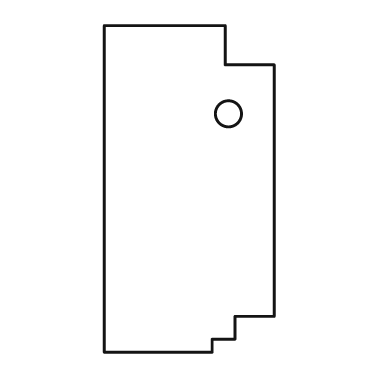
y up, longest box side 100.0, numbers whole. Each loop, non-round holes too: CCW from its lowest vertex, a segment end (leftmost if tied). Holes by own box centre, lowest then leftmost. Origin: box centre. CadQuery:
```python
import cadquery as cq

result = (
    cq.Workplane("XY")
    .moveTo(-26.0, -50.0)
    .lineTo(7.0, -50.0)
    .lineTo(7.0, -46.0)
    .lineTo(14.0, -46.0)
    .lineTo(14.0, -39.0)
    .lineTo(26.0, -39.0)
    .lineTo(26.0, 38.0)
    .lineTo(11.0, 38.0)
    .lineTo(11.0, 50.0)
    .lineTo(-26.0, 50.0)
    .close()
    .moveTo(12.0, 23.0)
    .circle(4.0)
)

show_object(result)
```